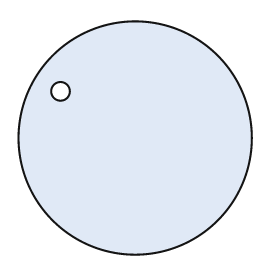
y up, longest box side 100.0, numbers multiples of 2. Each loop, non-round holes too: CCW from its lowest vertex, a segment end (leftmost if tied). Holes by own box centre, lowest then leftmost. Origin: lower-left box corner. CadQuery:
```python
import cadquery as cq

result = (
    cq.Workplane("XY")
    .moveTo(50.0, 50.0)
    .circle(50.0)
    .moveTo(18.0, 70.0)
    .circle(4.0)
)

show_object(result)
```